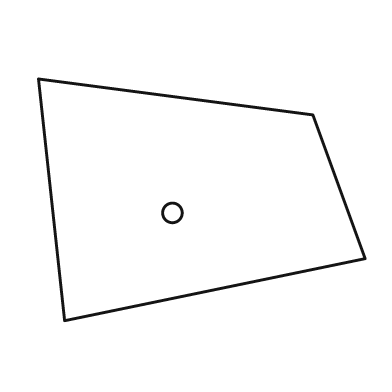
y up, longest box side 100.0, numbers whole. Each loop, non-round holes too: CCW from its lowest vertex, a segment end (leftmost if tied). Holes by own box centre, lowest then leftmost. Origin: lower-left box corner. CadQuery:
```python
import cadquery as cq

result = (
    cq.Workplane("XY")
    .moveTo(8.0, 0.0)
    .lineTo(100.0, 19.0)
    .lineTo(84.0, 63.0)
    .lineTo(0.0, 74.0)
    .close()
    .moveTo(41.0, 33.0)
    .circle(3.0)
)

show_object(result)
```